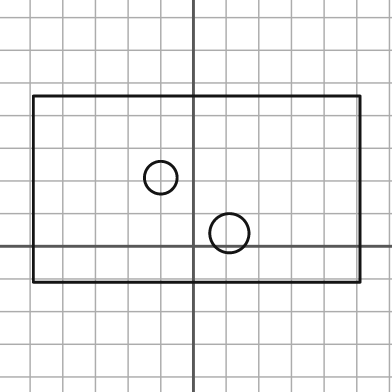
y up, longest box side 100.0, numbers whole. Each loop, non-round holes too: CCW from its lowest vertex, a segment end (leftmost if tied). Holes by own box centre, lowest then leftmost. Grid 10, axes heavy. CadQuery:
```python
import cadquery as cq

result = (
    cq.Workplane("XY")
    .moveTo(-49.0, -11.0)
    .lineTo(51.0, -11.0)
    .lineTo(51.0, 46.0)
    .lineTo(-49.0, 46.0)
    .close()
    .moveTo(11.0, 4.0)
    .circle(6.0)
    .moveTo(-10.0, 21.0)
    .circle(5.0)
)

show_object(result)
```